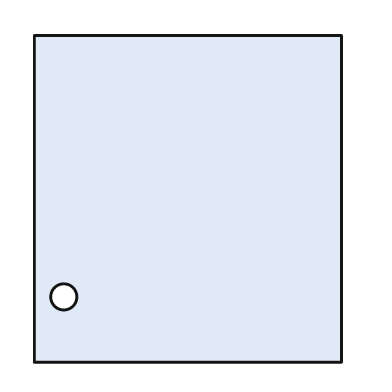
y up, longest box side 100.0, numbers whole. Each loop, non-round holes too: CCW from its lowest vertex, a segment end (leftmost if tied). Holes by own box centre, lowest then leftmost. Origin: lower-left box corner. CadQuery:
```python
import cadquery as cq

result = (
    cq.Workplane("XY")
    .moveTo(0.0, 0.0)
    .lineTo(94.0, 0.0)
    .lineTo(94.0, 100.0)
    .lineTo(0.0, 100.0)
    .close()
    .moveTo(9.0, 20.0)
    .circle(4.0)
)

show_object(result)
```